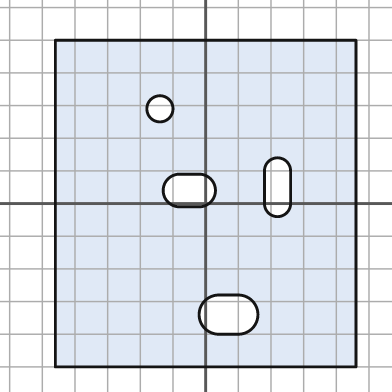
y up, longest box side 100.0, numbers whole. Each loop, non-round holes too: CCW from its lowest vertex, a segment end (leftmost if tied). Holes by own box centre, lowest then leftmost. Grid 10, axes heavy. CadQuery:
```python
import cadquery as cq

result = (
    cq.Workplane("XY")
    .moveTo(-46.0, -50.0)
    .lineTo(46.0, -50.0)
    .lineTo(46.0, 50.0)
    .lineTo(-46.0, 50.0)
    .close()
    .moveTo(4.0, -40.0)
    .lineTo(10.0, -40.0)
    .threePointArc((16.0, -34.0), (10.0, -28.0))
    .lineTo(4.0, -28.0)
    .threePointArc((-2.0, -34.0), (4.0, -40.0))
    .close()
    .moveTo(-8.0, -1.0)
    .lineTo(-2.0, -1.0)
    .threePointArc((3.0, 4.0), (-2.0, 9.0))
    .lineTo(-8.0, 9.0)
    .threePointArc((-13.0, 4.0), (-8.0, -1.0))
    .close()
    .moveTo(18.0, 0.0)
    .threePointArc((22.0, -4.0), (26.0, 0.0))
    .lineTo(26.0, 10.0)
    .threePointArc((22.0, 14.0), (18.0, 10.0))
    .close()
    .moveTo(-14.0, 29.0)
    .circle(4.0)
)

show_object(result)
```